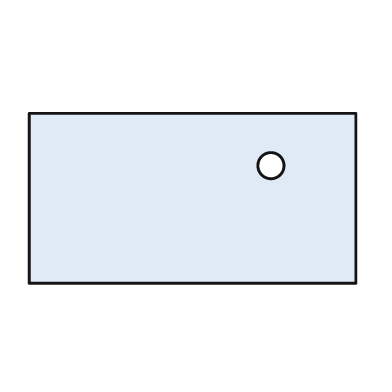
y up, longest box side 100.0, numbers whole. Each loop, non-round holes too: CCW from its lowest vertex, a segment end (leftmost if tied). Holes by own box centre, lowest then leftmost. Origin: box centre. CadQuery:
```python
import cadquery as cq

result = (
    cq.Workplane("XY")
    .moveTo(-50.0, -26.0)
    .lineTo(50.0, -26.0)
    .lineTo(50.0, 26.0)
    .lineTo(-50.0, 26.0)
    .close()
    .moveTo(24.0, 10.0)
    .circle(4.0)
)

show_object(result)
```